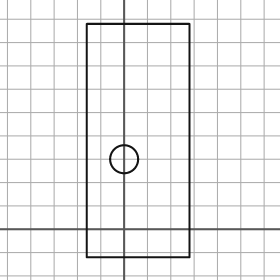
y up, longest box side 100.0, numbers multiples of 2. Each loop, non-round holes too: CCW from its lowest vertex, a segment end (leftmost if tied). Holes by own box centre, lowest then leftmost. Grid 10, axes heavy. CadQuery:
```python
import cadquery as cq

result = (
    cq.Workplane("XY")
    .moveTo(-16.0, -12.0)
    .lineTo(28.0, -12.0)
    .lineTo(28.0, 88.0)
    .lineTo(-16.0, 88.0)
    .close()
    .moveTo(0.0, 30.0)
    .circle(6.0)
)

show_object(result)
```